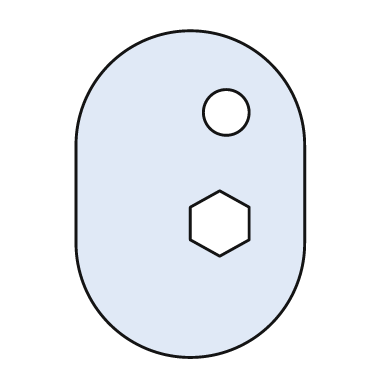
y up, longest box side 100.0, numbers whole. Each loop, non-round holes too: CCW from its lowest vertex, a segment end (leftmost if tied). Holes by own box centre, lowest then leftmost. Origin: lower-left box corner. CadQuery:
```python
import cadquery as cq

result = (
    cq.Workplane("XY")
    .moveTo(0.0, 35.0)
    .threePointArc((35.0, 0.0), (70.0, 35.0))
    .lineTo(70.0, 65.0)
    .threePointArc((35.0, 100.0), (0.0, 65.0))
    .close()
    .moveTo(44.0, 31.0)
    .lineTo(53.0, 36.0)
    .lineTo(53.0, 46.0)
    .lineTo(44.0, 51.0)
    .lineTo(35.0, 46.0)
    .lineTo(35.0, 36.0)
    .close()
    .moveTo(46.0, 75.0)
    .circle(7.0)
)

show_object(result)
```